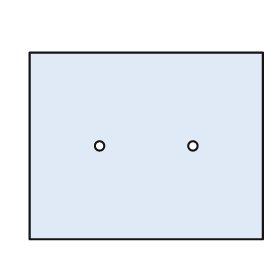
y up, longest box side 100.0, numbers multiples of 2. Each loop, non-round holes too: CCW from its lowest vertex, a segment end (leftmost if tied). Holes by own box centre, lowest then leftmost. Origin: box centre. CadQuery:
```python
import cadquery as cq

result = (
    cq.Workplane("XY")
    .moveTo(-50.0, -40.0)
    .lineTo(50.0, -40.0)
    .lineTo(50.0, 40.0)
    .lineTo(-50.0, 40.0)
    .close()
    .moveTo(-20.0, 0.0)
    .circle(2.0)
    .moveTo(20.0, 0.0)
    .circle(2.0)
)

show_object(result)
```